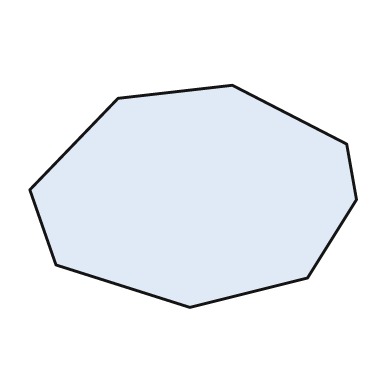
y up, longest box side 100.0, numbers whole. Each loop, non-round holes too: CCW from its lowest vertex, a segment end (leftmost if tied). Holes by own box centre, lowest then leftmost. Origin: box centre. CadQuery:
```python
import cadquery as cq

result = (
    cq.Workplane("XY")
    .moveTo(-1.0, -34.0)
    .lineTo(35.0, -25.0)
    .lineTo(50.0, -1.0)
    .lineTo(47.0, 16.0)
    .lineTo(12.0, 34.0)
    .lineTo(-23.0, 30.0)
    .lineTo(-50.0, 2.0)
    .lineTo(-42.0, -21.0)
    .close()
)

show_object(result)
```